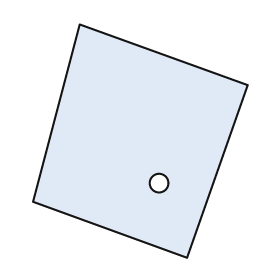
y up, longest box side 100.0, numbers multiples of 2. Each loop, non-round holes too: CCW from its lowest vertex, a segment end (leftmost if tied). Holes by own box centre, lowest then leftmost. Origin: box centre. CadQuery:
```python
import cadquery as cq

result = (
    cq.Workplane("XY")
    .moveTo(20.0, -50.0)
    .lineTo(46.0, 24.0)
    .lineTo(-26.0, 50.0)
    .lineTo(-46.0, -26.0)
    .close()
    .moveTo(8.0, -18.0)
    .circle(4.0)
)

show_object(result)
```